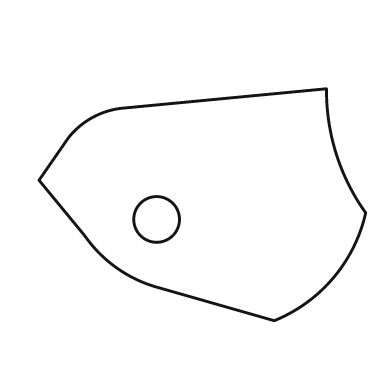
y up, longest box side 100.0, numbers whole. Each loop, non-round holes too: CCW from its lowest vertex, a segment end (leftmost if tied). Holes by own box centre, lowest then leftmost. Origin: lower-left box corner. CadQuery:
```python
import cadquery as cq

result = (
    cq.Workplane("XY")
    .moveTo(72.0, 0.0)
    .threePointArc((90.0, 13.0), (100.0, 33.0))
    .threePointArc((91.0, 51.0), (88.0, 71.0))
    .lineTo(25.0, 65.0)
    .threePointArc((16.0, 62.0), (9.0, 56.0))
    .lineTo(0.0, 43.0)
    .lineTo(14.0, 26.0)
    .threePointArc((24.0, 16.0), (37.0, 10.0))
    .close()
    .moveTo(36.0, 31.0)
    .circle(7.0)
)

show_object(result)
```